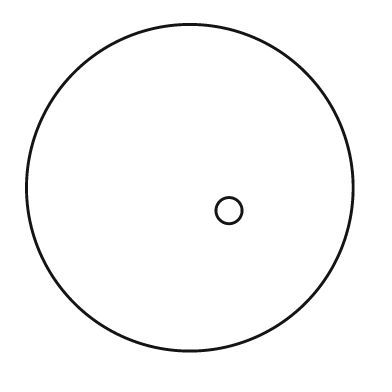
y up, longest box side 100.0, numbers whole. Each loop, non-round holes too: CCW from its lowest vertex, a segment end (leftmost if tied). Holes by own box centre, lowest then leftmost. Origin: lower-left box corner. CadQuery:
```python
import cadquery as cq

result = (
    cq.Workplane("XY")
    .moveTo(50.0, 50.0)
    .circle(50.0)
    .moveTo(62.0, 43.0)
    .circle(4.0)
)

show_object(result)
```